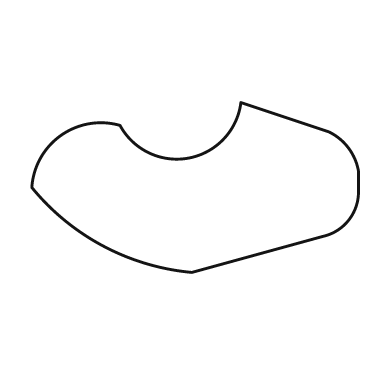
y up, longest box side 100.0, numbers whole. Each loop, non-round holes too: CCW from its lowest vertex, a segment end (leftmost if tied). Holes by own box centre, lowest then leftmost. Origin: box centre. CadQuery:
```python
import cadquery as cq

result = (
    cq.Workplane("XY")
    .moveTo(-1.0, -26.0)
    .lineTo(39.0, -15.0)
    .threePointArc((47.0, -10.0), (50.0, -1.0))
    .lineTo(50.0, 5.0)
    .threePointArc((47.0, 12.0), (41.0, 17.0))
    .lineTo(14.0, 26.0)
    .threePointArc((-2.0, 9.0), (-23.0, 19.0))
    .threePointArc((-41.0, 16.0), (-50.0, 0.0))
    .threePointArc((-28.0, -18.0), (-1.0, -26.0))
    .close()
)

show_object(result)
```